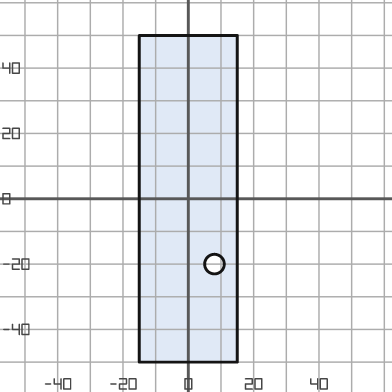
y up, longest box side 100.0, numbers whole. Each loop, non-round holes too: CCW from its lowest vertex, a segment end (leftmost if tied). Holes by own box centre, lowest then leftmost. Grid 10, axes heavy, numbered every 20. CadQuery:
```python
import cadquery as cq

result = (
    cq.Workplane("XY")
    .moveTo(-15.0, -50.0)
    .lineTo(15.0, -50.0)
    .lineTo(15.0, 50.0)
    .lineTo(-15.0, 50.0)
    .close()
    .moveTo(8.0, -20.0)
    .circle(3.0)
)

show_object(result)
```